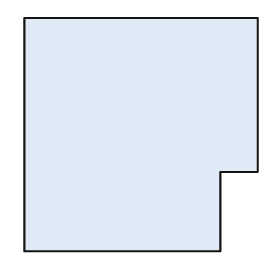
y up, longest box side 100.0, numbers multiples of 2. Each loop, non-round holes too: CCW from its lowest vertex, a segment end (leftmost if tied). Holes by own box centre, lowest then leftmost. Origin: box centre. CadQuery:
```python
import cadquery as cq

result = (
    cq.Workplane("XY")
    .moveTo(-50.0, -50.0)
    .lineTo(34.0, -50.0)
    .lineTo(34.0, -16.0)
    .lineTo(50.0, -16.0)
    .lineTo(50.0, 50.0)
    .lineTo(-50.0, 50.0)
    .close()
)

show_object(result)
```